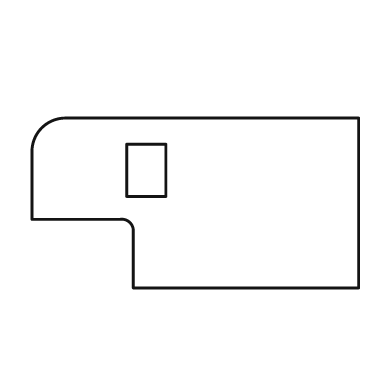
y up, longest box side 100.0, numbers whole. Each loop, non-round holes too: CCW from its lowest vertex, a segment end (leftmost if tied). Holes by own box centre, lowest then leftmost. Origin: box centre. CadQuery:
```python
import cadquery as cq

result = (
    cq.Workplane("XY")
    .moveTo(-19.0, -26.0)
    .lineTo(50.0, -26.0)
    .lineTo(50.0, 26.0)
    .lineTo(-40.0, 26.0)
    .threePointArc((-47.0, 23.0), (-50.0, 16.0))
    .lineTo(-50.0, -5.0)
    .lineTo(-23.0, -5.0)
    .threePointArc((-20.0, -6.0), (-19.0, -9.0))
    .close()
    .moveTo(-21.0, 2.0)
    .lineTo(-9.0, 2.0)
    .lineTo(-9.0, 18.0)
    .lineTo(-21.0, 18.0)
    .close()
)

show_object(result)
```